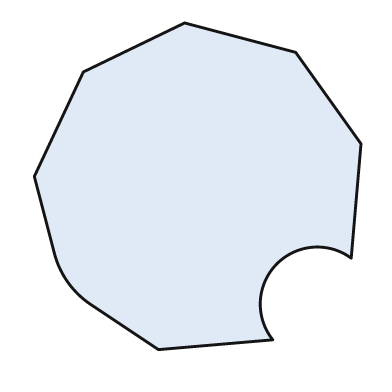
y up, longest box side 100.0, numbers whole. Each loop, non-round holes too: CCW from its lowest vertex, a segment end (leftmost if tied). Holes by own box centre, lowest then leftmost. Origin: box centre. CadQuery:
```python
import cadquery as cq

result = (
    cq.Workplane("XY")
    .moveTo(-12.0, -50.0)
    .lineTo(23.0, -47.0)
    .threePointArc((24.0, -24.0), (47.0, -22.0))
    .lineTo(50.0, 13.0)
    .lineTo(30.0, 41.0)
    .lineTo(-4.0, 50.0)
    .lineTo(-35.0, 35.0)
    .lineTo(-50.0, 3.0)
    .lineTo(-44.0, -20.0)
    .threePointArc((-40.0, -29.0), (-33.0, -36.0))
    .close()
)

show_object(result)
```